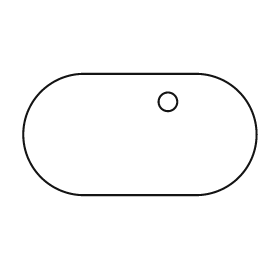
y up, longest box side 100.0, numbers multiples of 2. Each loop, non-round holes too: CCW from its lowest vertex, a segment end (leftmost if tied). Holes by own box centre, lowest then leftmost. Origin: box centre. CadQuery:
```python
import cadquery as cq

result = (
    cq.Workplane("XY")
    .moveTo(-24.0, -26.0)
    .lineTo(24.0, -26.0)
    .threePointArc((50.0, 0.0), (24.0, 26.0))
    .lineTo(-24.0, 26.0)
    .threePointArc((-50.0, 0.0), (-24.0, -26.0))
    .close()
    .moveTo(12.0, 14.0)
    .circle(4.0)
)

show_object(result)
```